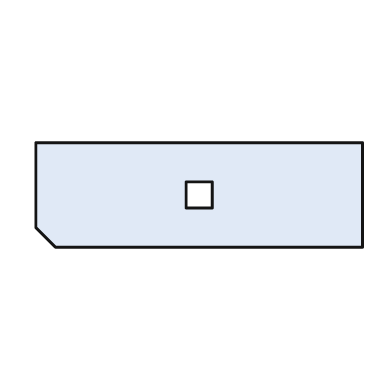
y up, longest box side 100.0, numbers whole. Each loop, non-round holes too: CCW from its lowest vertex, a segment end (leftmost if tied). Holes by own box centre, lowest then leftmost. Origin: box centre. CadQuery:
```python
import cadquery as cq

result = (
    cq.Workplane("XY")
    .moveTo(-44.0, -16.0)
    .lineTo(50.0, -16.0)
    .lineTo(50.0, 16.0)
    .lineTo(-50.0, 16.0)
    .lineTo(-50.0, -10.0)
    .close()
    .moveTo(-4.0, -4.0)
    .lineTo(4.0, -4.0)
    .lineTo(4.0, 4.0)
    .lineTo(-4.0, 4.0)
    .close()
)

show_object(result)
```